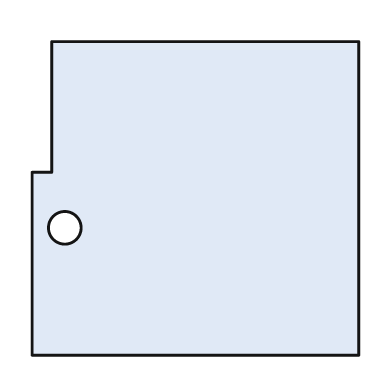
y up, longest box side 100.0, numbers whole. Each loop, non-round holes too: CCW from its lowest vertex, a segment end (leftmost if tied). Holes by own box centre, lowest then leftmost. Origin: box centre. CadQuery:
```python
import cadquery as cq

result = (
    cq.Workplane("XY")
    .moveTo(-50.0, -48.0)
    .lineTo(50.0, -48.0)
    .lineTo(50.0, 48.0)
    .lineTo(-44.0, 48.0)
    .lineTo(-44.0, 8.0)
    .lineTo(-50.0, 8.0)
    .close()
    .moveTo(-40.0, -9.0)
    .circle(5.0)
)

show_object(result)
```